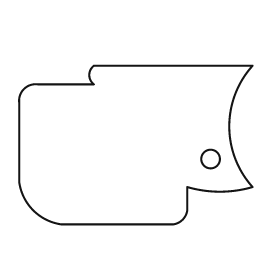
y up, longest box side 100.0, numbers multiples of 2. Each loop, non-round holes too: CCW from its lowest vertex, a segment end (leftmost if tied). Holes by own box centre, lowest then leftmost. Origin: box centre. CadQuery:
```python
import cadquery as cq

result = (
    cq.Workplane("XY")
    .moveTo(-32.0, -34.0)
    .lineTo(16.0, -34.0)
    .threePointArc((20.0, -32.0), (22.0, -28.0))
    .lineTo(22.0, -18.0)
    .threePointArc((36.0, -20.0), (50.0, -18.0))
    .threePointArc((40.0, 8.0), (50.0, 34.0))
    .lineTo(-18.0, 34.0)
    .threePointArc((-20.0, 30.0), (-18.0, 26.0))
    .lineTo(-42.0, 26.0)
    .threePointArc((-48.0, 24.0), (-50.0, 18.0))
    .lineTo(-50.0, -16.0)
    .threePointArc((-44.0, -28.0), (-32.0, -34.0))
    .close()
    .moveTo(32.0, -6.0)
    .circle(4.0)
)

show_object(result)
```